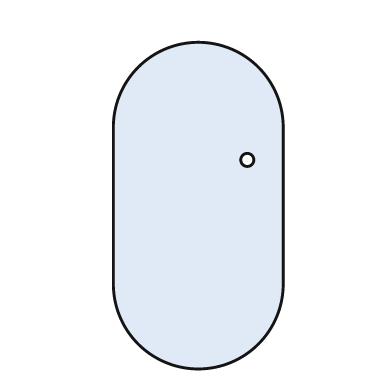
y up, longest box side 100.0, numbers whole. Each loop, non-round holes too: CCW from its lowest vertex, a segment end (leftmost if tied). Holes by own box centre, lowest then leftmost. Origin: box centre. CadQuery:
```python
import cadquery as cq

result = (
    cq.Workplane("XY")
    .moveTo(-26.0, -24.0)
    .threePointArc((0.0, -50.0), (26.0, -24.0))
    .lineTo(26.0, 24.0)
    .threePointArc((0.0, 50.0), (-26.0, 24.0))
    .close()
    .moveTo(15.0, 14.0)
    .circle(2.0)
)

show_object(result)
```